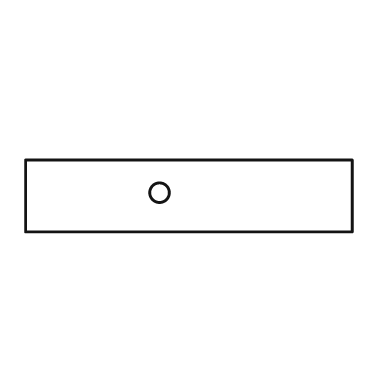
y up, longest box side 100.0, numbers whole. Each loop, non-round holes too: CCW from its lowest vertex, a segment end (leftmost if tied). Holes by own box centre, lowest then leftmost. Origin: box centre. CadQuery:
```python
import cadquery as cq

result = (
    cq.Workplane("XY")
    .moveTo(-50.0, -11.0)
    .lineTo(50.0, -11.0)
    .lineTo(50.0, 11.0)
    .lineTo(-50.0, 11.0)
    .close()
    .moveTo(-9.0, 1.0)
    .circle(3.0)
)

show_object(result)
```